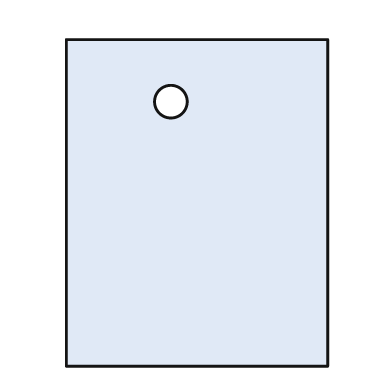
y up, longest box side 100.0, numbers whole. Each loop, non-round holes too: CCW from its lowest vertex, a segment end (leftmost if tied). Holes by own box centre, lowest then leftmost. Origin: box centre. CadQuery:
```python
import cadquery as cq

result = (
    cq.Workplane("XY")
    .moveTo(-40.0, -50.0)
    .lineTo(40.0, -50.0)
    .lineTo(40.0, 50.0)
    .lineTo(-40.0, 50.0)
    .close()
    .moveTo(-8.0, 31.0)
    .circle(5.0)
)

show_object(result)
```